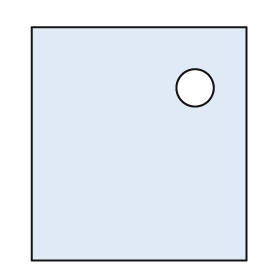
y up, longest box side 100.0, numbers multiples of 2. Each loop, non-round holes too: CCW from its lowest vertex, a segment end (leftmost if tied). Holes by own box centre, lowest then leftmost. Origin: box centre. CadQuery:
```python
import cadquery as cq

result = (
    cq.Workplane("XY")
    .moveTo(-46.0, -50.0)
    .lineTo(46.0, -50.0)
    .lineTo(46.0, 50.0)
    .lineTo(-46.0, 50.0)
    .close()
    .moveTo(24.0, 24.0)
    .circle(8.0)
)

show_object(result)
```